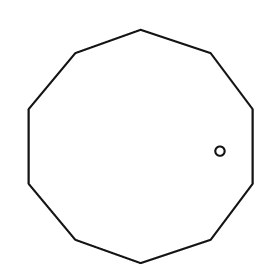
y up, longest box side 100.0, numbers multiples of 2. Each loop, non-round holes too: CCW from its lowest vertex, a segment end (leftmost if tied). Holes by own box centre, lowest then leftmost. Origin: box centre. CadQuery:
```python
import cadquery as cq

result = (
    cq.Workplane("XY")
    .moveTo(0.0, -50.0)
    .lineTo(30.0, -40.0)
    .lineTo(48.0, -16.0)
    .lineTo(48.0, 16.0)
    .lineTo(30.0, 40.0)
    .lineTo(0.0, 50.0)
    .lineTo(-28.0, 40.0)
    .lineTo(-48.0, 16.0)
    .lineTo(-48.0, -16.0)
    .lineTo(-28.0, -40.0)
    .close()
    .moveTo(34.0, -2.0)
    .circle(2.0)
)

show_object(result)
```